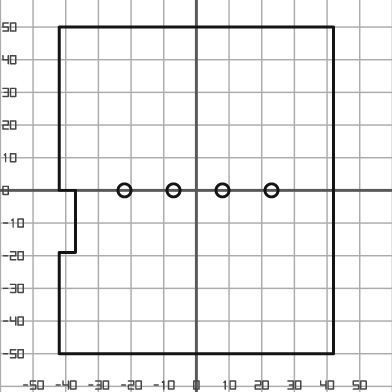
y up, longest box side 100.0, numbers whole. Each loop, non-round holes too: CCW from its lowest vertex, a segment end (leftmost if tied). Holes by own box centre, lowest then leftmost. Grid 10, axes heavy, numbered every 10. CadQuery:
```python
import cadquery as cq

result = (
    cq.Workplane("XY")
    .moveTo(-42.0, -50.0)
    .lineTo(42.0, -50.0)
    .lineTo(42.0, 50.0)
    .lineTo(-42.0, 50.0)
    .lineTo(-42.0, 0.0)
    .lineTo(-37.0, 0.0)
    .lineTo(-37.0, -19.0)
    .lineTo(-42.0, -19.0)
    .close()
    .moveTo(-22.0, 0.0)
    .circle(2.0)
    .moveTo(-7.0, 0.0)
    .circle(2.0)
    .moveTo(8.0, 0.0)
    .circle(2.0)
    .moveTo(23.0, 0.0)
    .circle(2.0)
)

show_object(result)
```